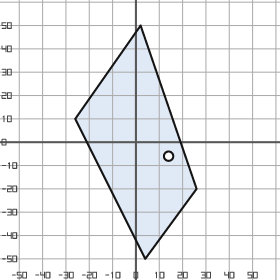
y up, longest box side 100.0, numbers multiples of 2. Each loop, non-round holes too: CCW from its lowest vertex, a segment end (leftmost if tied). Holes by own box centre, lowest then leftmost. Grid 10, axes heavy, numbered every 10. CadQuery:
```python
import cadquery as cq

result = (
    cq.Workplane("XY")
    .moveTo(4.0, -50.0)
    .lineTo(26.0, -20.0)
    .lineTo(2.0, 50.0)
    .lineTo(-26.0, 10.0)
    .close()
    .moveTo(14.0, -6.0)
    .circle(2.0)
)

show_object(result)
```